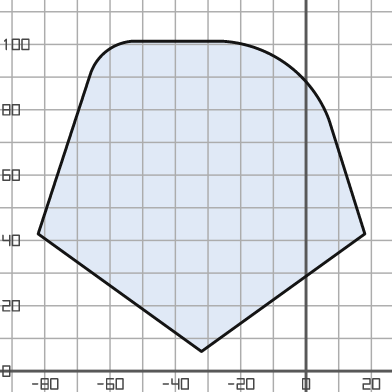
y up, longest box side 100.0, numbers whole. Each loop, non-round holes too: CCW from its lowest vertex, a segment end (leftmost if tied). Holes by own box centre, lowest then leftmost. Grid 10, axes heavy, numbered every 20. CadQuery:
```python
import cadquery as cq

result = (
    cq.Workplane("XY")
    .moveTo(-32.0, 6.0)
    .lineTo(18.0, 42.0)
    .lineTo(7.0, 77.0)
    .threePointArc((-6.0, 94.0), (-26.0, 101.0))
    .lineTo(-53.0, 101.0)
    .threePointArc((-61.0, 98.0), (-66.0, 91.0))
    .lineTo(-82.0, 42.0)
    .close()
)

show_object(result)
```